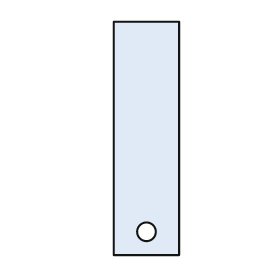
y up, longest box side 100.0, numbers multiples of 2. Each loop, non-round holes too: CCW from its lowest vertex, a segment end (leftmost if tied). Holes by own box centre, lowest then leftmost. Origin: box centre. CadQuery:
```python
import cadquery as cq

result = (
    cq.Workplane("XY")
    .moveTo(-14.0, -50.0)
    .lineTo(14.0, -50.0)
    .lineTo(14.0, 50.0)
    .lineTo(-14.0, 50.0)
    .close()
    .moveTo(0.0, -40.0)
    .circle(4.0)
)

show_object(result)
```